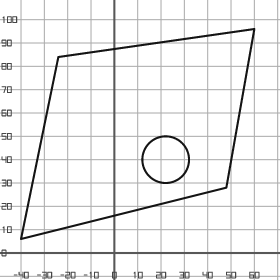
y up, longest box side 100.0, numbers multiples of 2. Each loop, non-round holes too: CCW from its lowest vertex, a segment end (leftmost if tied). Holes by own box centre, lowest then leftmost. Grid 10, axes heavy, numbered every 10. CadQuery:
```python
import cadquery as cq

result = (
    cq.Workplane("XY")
    .moveTo(-40.0, 6.0)
    .lineTo(48.0, 28.0)
    .lineTo(60.0, 96.0)
    .lineTo(-24.0, 84.0)
    .close()
    .moveTo(22.0, 40.0)
    .circle(10.0)
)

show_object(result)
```